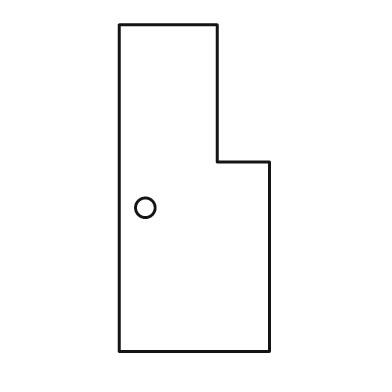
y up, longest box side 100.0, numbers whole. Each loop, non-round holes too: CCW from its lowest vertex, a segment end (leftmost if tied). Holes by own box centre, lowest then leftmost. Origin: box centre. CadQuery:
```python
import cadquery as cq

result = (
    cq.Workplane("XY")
    .moveTo(-23.0, -50.0)
    .lineTo(23.0, -50.0)
    .lineTo(23.0, 8.0)
    .lineTo(7.0, 8.0)
    .lineTo(7.0, 50.0)
    .lineTo(-23.0, 50.0)
    .close()
    .moveTo(-15.0, -6.0)
    .circle(3.0)
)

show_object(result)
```